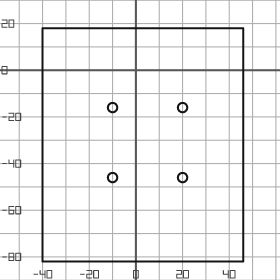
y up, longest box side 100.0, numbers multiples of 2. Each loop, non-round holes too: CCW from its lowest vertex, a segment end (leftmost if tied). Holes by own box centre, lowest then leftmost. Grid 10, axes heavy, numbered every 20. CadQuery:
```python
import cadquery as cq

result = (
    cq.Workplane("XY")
    .moveTo(-40.0, -82.0)
    .lineTo(46.0, -82.0)
    .lineTo(46.0, 18.0)
    .lineTo(-40.0, 18.0)
    .close()
    .moveTo(-10.0, -46.0)
    .circle(2.0)
    .moveTo(20.0, -46.0)
    .circle(2.0)
    .moveTo(-10.0, -16.0)
    .circle(2.0)
    .moveTo(20.0, -16.0)
    .circle(2.0)
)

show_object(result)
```